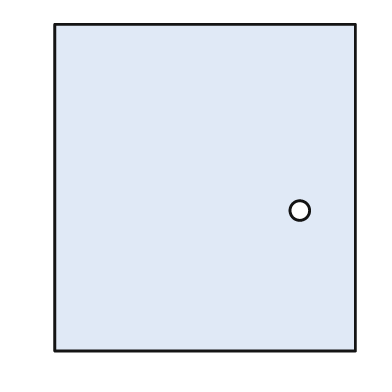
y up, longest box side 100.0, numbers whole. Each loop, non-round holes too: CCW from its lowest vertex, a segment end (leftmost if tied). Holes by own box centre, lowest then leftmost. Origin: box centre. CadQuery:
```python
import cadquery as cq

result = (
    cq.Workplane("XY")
    .moveTo(-46.0, -50.0)
    .lineTo(46.0, -50.0)
    .lineTo(46.0, 50.0)
    .lineTo(-46.0, 50.0)
    .close()
    .moveTo(29.0, -7.0)
    .circle(3.0)
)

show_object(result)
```